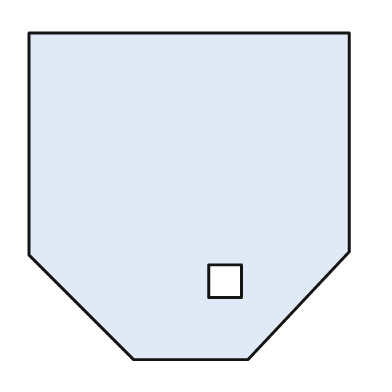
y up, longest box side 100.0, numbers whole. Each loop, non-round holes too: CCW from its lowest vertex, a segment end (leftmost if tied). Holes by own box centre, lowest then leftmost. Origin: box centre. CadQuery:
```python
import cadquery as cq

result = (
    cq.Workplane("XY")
    .moveTo(-17.0, -50.0)
    .lineTo(18.0, -50.0)
    .lineTo(49.0, -17.0)
    .lineTo(49.0, 50.0)
    .lineTo(-49.0, 50.0)
    .lineTo(-49.0, -18.0)
    .close()
    .moveTo(6.0, -31.0)
    .lineTo(16.0, -31.0)
    .lineTo(16.0, -21.0)
    .lineTo(6.0, -21.0)
    .close()
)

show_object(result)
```